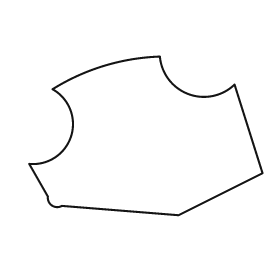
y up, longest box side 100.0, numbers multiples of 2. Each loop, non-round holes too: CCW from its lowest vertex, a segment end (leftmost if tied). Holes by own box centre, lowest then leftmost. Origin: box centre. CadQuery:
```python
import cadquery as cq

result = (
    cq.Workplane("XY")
    .moveTo(14.0, -34.0)
    .lineTo(50.0, -16.0)
    .lineTo(38.0, 22.0)
    .threePointArc((18.0, 18.0), (6.0, 34.0))
    .threePointArc((-18.0, 30.0), (-40.0, 20.0))
    .threePointArc((-32.0, 0.0), (-50.0, -12.0))
    .lineTo(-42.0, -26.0)
    .threePointArc((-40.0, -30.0), (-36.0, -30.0))
    .close()
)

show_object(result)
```